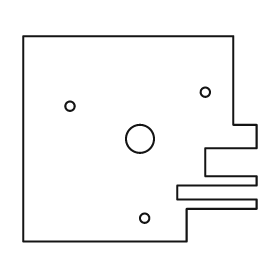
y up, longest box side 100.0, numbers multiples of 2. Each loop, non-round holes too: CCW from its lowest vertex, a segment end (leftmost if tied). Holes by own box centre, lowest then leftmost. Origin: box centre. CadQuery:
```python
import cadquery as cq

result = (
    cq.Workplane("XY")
    .moveTo(-50.0, -44.0)
    .lineTo(20.0, -44.0)
    .lineTo(20.0, -30.0)
    .lineTo(50.0, -30.0)
    .lineTo(50.0, -26.0)
    .lineTo(16.0, -26.0)
    .lineTo(16.0, -20.0)
    .lineTo(50.0, -20.0)
    .lineTo(50.0, -16.0)
    .lineTo(28.0, -16.0)
    .lineTo(28.0, -4.0)
    .lineTo(50.0, -4.0)
    .lineTo(50.0, 6.0)
    .lineTo(40.0, 6.0)
    .lineTo(40.0, 44.0)
    .lineTo(-50.0, 44.0)
    .close()
    .moveTo(2.0, -34.0)
    .circle(2.0)
    .moveTo(0.0, 0.0)
    .circle(6.0)
    .moveTo(-30.0, 14.0)
    .circle(2.0)
    .moveTo(28.0, 20.0)
    .circle(2.0)
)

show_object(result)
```